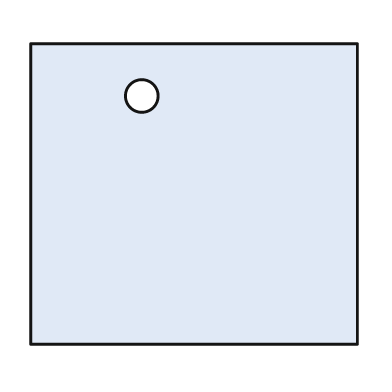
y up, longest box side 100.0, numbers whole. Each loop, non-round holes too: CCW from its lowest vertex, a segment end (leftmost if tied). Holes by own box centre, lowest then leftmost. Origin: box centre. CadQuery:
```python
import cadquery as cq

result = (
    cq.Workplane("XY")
    .moveTo(-50.0, -46.0)
    .lineTo(50.0, -46.0)
    .lineTo(50.0, 46.0)
    .lineTo(-50.0, 46.0)
    .close()
    .moveTo(-16.0, 30.0)
    .circle(5.0)
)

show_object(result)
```